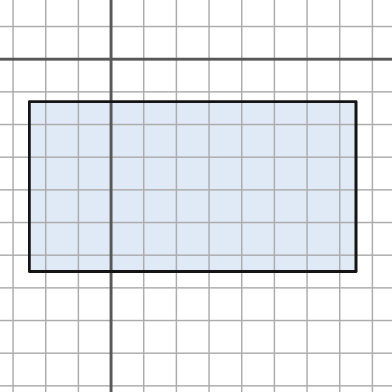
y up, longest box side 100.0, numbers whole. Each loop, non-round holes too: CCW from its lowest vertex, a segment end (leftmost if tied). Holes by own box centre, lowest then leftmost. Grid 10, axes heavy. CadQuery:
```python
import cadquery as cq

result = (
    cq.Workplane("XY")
    .moveTo(-25.0, -65.0)
    .lineTo(75.0, -65.0)
    .lineTo(75.0, -13.0)
    .lineTo(-25.0, -13.0)
    .close()
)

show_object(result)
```